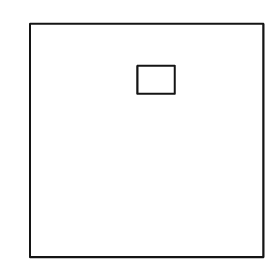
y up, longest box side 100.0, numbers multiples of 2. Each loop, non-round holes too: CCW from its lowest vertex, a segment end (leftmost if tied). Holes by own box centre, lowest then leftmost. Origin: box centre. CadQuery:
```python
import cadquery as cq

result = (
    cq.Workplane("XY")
    .moveTo(-50.0, -50.0)
    .lineTo(50.0, -50.0)
    .lineTo(50.0, 50.0)
    .lineTo(-50.0, 50.0)
    .close()
    .moveTo(-4.0, 20.0)
    .lineTo(12.0, 20.0)
    .lineTo(12.0, 32.0)
    .lineTo(-4.0, 32.0)
    .close()
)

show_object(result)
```